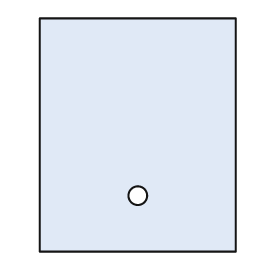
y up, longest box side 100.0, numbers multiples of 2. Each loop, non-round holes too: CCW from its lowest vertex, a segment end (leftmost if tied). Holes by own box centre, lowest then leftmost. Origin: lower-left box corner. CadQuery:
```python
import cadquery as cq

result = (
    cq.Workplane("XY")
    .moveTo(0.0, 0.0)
    .lineTo(84.0, 0.0)
    .lineTo(84.0, 100.0)
    .lineTo(0.0, 100.0)
    .close()
    .moveTo(42.0, 24.0)
    .circle(4.0)
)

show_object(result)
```